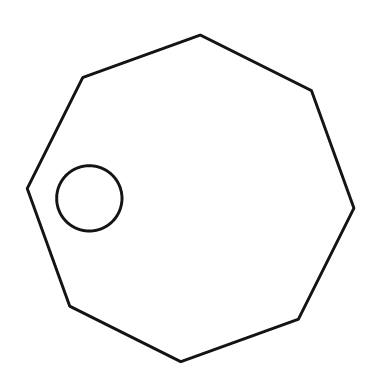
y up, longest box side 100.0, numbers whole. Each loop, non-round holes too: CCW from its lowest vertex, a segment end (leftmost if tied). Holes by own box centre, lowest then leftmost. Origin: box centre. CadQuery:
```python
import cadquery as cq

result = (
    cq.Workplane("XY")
    .moveTo(-3.0, -50.0)
    .lineTo(33.0, -37.0)
    .lineTo(50.0, -3.0)
    .lineTo(37.0, 33.0)
    .lineTo(3.0, 50.0)
    .lineTo(-33.0, 37.0)
    .lineTo(-50.0, 3.0)
    .lineTo(-37.0, -33.0)
    .close()
    .moveTo(-31.0, 0.0)
    .circle(10.0)
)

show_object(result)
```